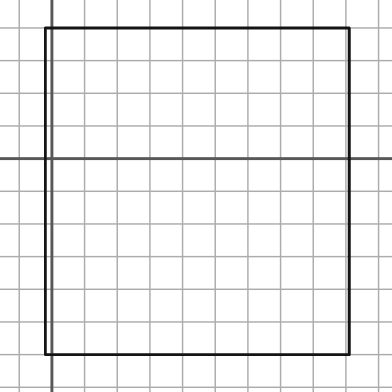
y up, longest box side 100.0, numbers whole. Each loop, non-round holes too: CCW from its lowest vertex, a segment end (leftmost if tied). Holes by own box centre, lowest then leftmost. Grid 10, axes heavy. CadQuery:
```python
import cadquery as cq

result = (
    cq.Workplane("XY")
    .moveTo(-2.0, -60.0)
    .lineTo(91.0, -60.0)
    .lineTo(91.0, 40.0)
    .lineTo(-2.0, 40.0)
    .close()
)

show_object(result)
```